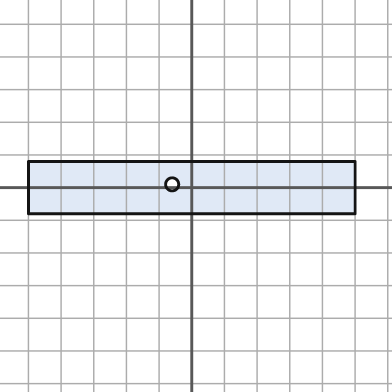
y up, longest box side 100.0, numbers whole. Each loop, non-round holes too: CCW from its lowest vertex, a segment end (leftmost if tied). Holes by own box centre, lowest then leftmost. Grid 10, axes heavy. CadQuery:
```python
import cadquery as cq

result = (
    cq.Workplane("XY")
    .moveTo(-50.0, -8.0)
    .lineTo(50.0, -8.0)
    .lineTo(50.0, 8.0)
    .lineTo(-50.0, 8.0)
    .close()
    .moveTo(-6.0, 1.0)
    .circle(2.0)
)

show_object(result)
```